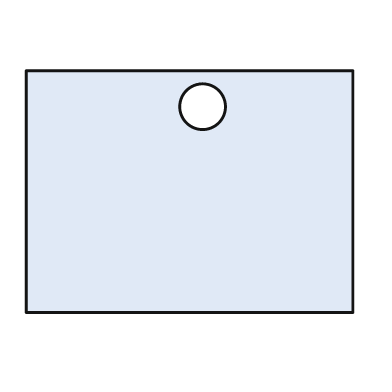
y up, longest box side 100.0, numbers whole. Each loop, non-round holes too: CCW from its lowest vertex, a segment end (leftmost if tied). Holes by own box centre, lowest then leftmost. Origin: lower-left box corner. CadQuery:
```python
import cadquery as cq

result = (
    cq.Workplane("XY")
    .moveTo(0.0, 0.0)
    .lineTo(100.0, 0.0)
    .lineTo(100.0, 74.0)
    .lineTo(0.0, 74.0)
    .close()
    .moveTo(54.0, 63.0)
    .circle(7.0)
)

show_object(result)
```